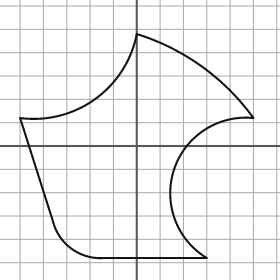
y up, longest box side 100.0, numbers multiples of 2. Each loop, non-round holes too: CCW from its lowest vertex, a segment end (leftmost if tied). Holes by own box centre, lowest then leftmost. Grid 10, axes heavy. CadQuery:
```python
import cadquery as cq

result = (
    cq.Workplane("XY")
    .moveTo(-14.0, -48.0)
    .lineTo(30.0, -48.0)
    .threePointArc((16.0, -10.0), (50.0, 12.0))
    .threePointArc((28.0, 34.0), (0.0, 48.0))
    .threePointArc((-18.0, 20.0), (-50.0, 12.0))
    .lineTo(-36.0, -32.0)
    .threePointArc((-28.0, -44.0), (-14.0, -48.0))
    .close()
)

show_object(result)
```